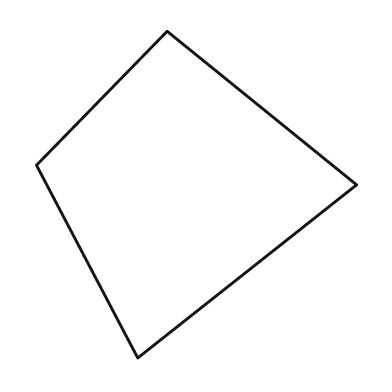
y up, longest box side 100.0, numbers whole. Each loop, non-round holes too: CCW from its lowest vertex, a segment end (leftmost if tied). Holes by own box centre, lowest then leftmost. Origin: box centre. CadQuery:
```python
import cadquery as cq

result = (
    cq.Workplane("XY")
    .moveTo(-18.0, -50.0)
    .lineTo(49.0, 3.0)
    .lineTo(-9.0, 50.0)
    .lineTo(-49.0, 9.0)
    .close()
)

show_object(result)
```